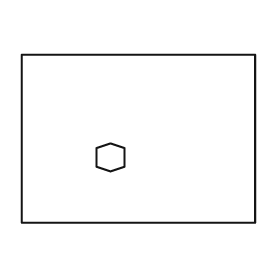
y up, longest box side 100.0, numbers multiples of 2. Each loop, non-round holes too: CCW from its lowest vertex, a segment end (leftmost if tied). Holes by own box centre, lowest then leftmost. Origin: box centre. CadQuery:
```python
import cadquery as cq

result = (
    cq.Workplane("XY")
    .moveTo(-50.0, -36.0)
    .lineTo(50.0, -36.0)
    .lineTo(50.0, 36.0)
    .lineTo(-50.0, 36.0)
    .close()
    .moveTo(-12.0, -14.0)
    .lineTo(-6.0, -12.0)
    .lineTo(-6.0, -4.0)
    .lineTo(-12.0, -2.0)
    .lineTo(-18.0, -4.0)
    .lineTo(-18.0, -12.0)
    .close()
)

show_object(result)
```